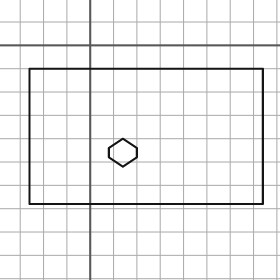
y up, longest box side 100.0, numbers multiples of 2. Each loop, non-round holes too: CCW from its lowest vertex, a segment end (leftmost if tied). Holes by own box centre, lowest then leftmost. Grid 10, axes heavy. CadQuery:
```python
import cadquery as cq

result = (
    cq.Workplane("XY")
    .moveTo(-26.0, -68.0)
    .lineTo(74.0, -68.0)
    .lineTo(74.0, -10.0)
    .lineTo(-26.0, -10.0)
    .close()
    .moveTo(14.0, -52.0)
    .lineTo(20.0, -48.0)
    .lineTo(20.0, -44.0)
    .lineTo(14.0, -40.0)
    .lineTo(8.0, -44.0)
    .lineTo(8.0, -48.0)
    .close()
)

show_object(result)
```